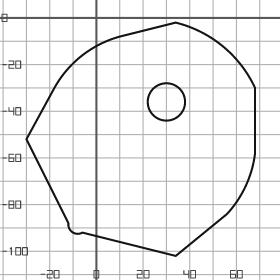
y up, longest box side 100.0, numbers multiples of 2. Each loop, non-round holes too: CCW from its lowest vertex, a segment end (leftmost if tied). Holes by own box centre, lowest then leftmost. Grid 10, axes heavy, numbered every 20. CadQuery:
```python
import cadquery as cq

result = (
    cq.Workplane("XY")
    .moveTo(34.0, -102.0)
    .lineTo(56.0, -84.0)
    .threePointArc((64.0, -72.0), (68.0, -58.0))
    .lineTo(68.0, -30.0)
    .threePointArc((54.0, -12.0), (34.0, -2.0))
    .lineTo(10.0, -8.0)
    .threePointArc((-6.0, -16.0), (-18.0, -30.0))
    .lineTo(-30.0, -52.0)
    .lineTo(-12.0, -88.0)
    .threePointArc((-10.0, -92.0), (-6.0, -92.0))
    .close()
    .moveTo(30.0, -36.0)
    .circle(8.0)
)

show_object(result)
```